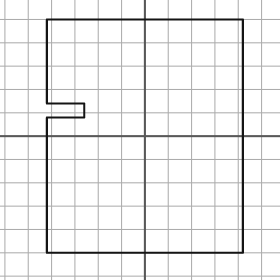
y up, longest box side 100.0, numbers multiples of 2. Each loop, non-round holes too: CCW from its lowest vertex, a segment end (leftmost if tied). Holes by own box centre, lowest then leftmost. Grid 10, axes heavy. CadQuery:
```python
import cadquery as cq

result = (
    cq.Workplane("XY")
    .moveTo(-42.0, -50.0)
    .lineTo(42.0, -50.0)
    .lineTo(42.0, 50.0)
    .lineTo(-42.0, 50.0)
    .lineTo(-42.0, 14.0)
    .lineTo(-26.0, 14.0)
    .lineTo(-26.0, 8.0)
    .lineTo(-42.0, 8.0)
    .close()
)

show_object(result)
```